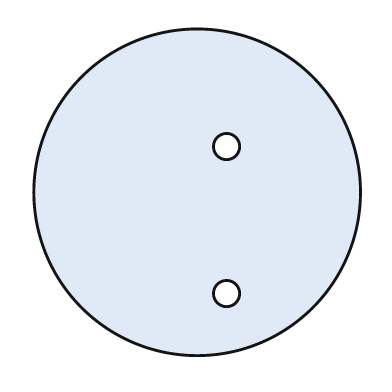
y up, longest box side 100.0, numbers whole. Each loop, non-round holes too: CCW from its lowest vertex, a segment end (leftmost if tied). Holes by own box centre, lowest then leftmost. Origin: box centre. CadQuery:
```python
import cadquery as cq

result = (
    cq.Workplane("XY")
    .moveTo(0.0, 0.0)
    .circle(50.0)
    .moveTo(9.0, -31.0)
    .circle(4.0)
    .moveTo(9.0, 14.0)
    .circle(4.0)
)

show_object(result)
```